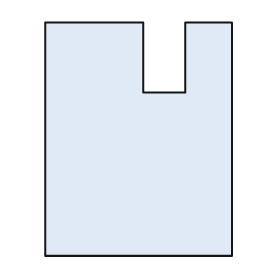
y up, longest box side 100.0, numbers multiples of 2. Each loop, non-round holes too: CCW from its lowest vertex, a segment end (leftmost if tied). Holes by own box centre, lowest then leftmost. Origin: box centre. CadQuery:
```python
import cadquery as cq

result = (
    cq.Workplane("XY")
    .moveTo(-40.0, -50.0)
    .lineTo(40.0, -50.0)
    .lineTo(40.0, 50.0)
    .lineTo(20.0, 50.0)
    .lineTo(20.0, 20.0)
    .lineTo(2.0, 20.0)
    .lineTo(2.0, 50.0)
    .lineTo(-40.0, 50.0)
    .close()
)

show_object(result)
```